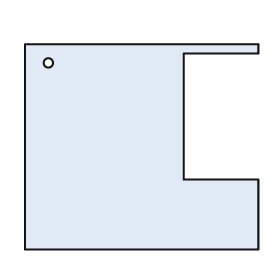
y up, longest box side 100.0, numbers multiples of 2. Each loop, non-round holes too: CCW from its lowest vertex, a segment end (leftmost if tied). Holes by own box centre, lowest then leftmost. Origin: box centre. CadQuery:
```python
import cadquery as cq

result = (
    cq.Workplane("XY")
    .moveTo(-50.0, -44.0)
    .lineTo(50.0, -44.0)
    .lineTo(50.0, -14.0)
    .lineTo(18.0, -14.0)
    .lineTo(18.0, 40.0)
    .lineTo(50.0, 40.0)
    .lineTo(50.0, 44.0)
    .lineTo(-50.0, 44.0)
    .close()
    .moveTo(-40.0, 36.0)
    .circle(2.0)
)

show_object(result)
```